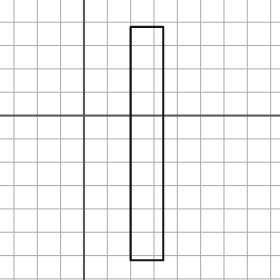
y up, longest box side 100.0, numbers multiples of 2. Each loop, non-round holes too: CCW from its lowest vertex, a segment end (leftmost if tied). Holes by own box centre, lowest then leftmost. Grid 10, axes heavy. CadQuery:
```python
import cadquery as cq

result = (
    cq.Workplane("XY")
    .moveTo(20.0, -62.0)
    .lineTo(34.0, -62.0)
    .lineTo(34.0, 38.0)
    .lineTo(20.0, 38.0)
    .close()
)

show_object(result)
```